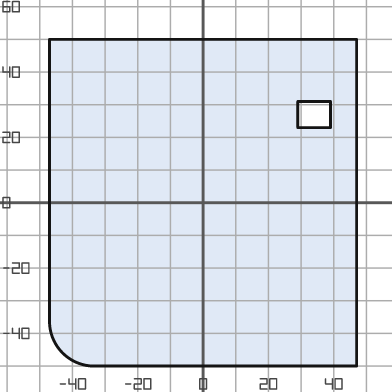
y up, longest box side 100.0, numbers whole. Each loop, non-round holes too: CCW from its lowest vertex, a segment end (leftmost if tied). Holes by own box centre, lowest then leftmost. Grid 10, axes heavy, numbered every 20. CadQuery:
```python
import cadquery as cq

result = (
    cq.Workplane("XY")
    .moveTo(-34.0, -50.0)
    .lineTo(47.0, -50.0)
    .lineTo(47.0, 50.0)
    .lineTo(-47.0, 50.0)
    .lineTo(-47.0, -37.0)
    .threePointArc((-43.0, -46.0), (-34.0, -50.0))
    .close()
    .moveTo(29.0, 23.0)
    .lineTo(39.0, 23.0)
    .lineTo(39.0, 31.0)
    .lineTo(29.0, 31.0)
    .close()
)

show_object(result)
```